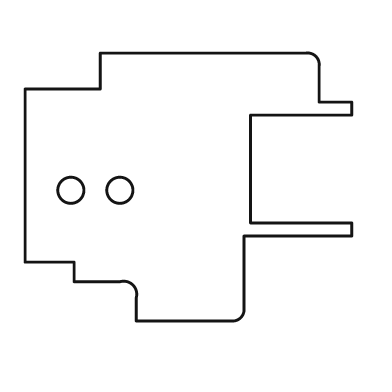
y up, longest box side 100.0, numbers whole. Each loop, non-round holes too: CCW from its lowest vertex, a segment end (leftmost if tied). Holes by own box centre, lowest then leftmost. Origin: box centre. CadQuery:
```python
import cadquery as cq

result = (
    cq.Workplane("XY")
    .moveTo(-16.0, -41.0)
    .lineTo(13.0, -41.0)
    .threePointArc((16.0, -40.0), (17.0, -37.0))
    .lineTo(17.0, -15.0)
    .lineTo(50.0, -15.0)
    .lineTo(50.0, -11.0)
    .lineTo(19.0, -11.0)
    .lineTo(19.0, 22.0)
    .lineTo(50.0, 22.0)
    .lineTo(50.0, 26.0)
    .lineTo(40.0, 26.0)
    .lineTo(40.0, 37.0)
    .threePointArc((39.0, 40.0), (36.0, 41.0))
    .lineTo(-27.0, 41.0)
    .lineTo(-27.0, 30.0)
    .lineTo(-50.0, 30.0)
    .lineTo(-50.0, -23.0)
    .lineTo(-35.0, -23.0)
    .lineTo(-35.0, -29.0)
    .lineTo(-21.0, -29.0)
    .threePointArc((-17.0, -30.0), (-16.0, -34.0))
    .close()
    .moveTo(-36.0, -1.0)
    .circle(4.0)
    .moveTo(-21.0, -1.0)
    .circle(4.0)
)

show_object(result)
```